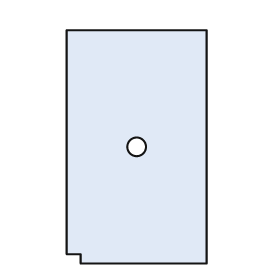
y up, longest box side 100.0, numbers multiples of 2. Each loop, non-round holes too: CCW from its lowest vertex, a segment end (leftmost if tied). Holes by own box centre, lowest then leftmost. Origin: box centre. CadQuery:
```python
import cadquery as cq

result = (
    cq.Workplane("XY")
    .moveTo(-24.0, -50.0)
    .lineTo(30.0, -50.0)
    .lineTo(30.0, 50.0)
    .lineTo(-30.0, 50.0)
    .lineTo(-30.0, -46.0)
    .lineTo(-24.0, -46.0)
    .close()
    .moveTo(0.0, 0.0)
    .circle(4.0)
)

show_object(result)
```